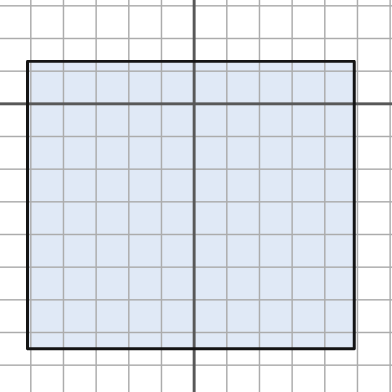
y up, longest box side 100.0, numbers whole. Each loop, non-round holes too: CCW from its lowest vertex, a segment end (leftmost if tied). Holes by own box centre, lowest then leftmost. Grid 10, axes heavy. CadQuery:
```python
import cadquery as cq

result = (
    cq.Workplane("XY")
    .moveTo(-51.0, -75.0)
    .lineTo(49.0, -75.0)
    .lineTo(49.0, 13.0)
    .lineTo(-51.0, 13.0)
    .close()
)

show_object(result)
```